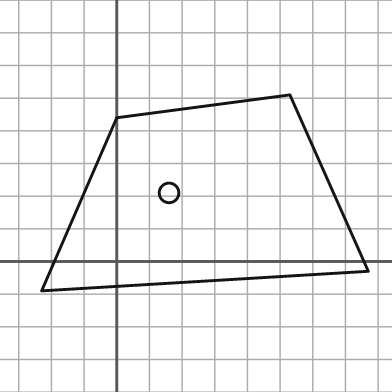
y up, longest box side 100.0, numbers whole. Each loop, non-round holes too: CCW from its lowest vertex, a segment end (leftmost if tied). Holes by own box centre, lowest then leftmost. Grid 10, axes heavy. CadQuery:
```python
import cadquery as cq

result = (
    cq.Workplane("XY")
    .moveTo(-23.0, -9.0)
    .lineTo(77.0, -3.0)
    .lineTo(53.0, 51.0)
    .lineTo(0.0, 44.0)
    .close()
    .moveTo(16.0, 21.0)
    .circle(3.0)
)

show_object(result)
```